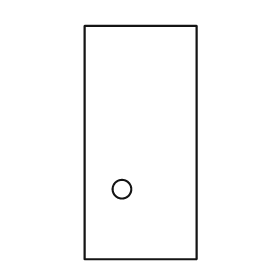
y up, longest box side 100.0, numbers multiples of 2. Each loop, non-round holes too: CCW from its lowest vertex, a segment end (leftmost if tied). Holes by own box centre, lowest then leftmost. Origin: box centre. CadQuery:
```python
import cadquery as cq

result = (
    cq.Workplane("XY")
    .moveTo(-24.0, -50.0)
    .lineTo(24.0, -50.0)
    .lineTo(24.0, 50.0)
    .lineTo(-24.0, 50.0)
    .close()
    .moveTo(-8.0, -20.0)
    .circle(4.0)
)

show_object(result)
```